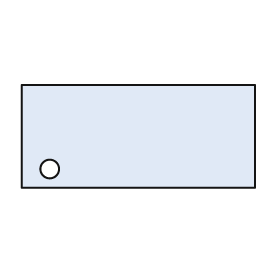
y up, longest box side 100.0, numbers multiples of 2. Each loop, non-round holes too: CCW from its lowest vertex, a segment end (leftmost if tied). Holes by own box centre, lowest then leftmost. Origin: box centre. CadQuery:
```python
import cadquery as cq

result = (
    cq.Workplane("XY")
    .moveTo(-50.0, -22.0)
    .lineTo(50.0, -22.0)
    .lineTo(50.0, 22.0)
    .lineTo(-50.0, 22.0)
    .close()
    .moveTo(-38.0, -14.0)
    .circle(4.0)
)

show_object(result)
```